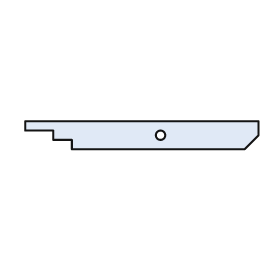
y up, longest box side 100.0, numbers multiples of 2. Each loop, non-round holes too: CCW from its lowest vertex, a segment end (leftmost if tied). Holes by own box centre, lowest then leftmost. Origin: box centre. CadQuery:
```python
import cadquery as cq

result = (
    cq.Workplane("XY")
    .moveTo(-30.0, -6.0)
    .lineTo(44.0, -6.0)
    .lineTo(50.0, 0.0)
    .lineTo(50.0, 6.0)
    .lineTo(-50.0, 6.0)
    .lineTo(-50.0, 2.0)
    .lineTo(-38.0, 2.0)
    .lineTo(-38.0, -2.0)
    .lineTo(-30.0, -2.0)
    .close()
    .moveTo(8.0, 0.0)
    .circle(2.0)
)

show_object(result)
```